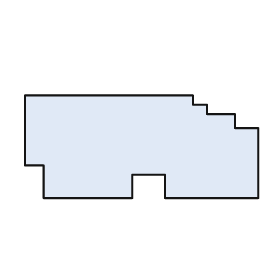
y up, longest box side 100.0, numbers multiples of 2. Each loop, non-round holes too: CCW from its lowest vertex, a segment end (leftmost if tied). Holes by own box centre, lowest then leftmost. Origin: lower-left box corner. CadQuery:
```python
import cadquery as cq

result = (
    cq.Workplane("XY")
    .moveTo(8.0, 0.0)
    .lineTo(46.0, 0.0)
    .lineTo(46.0, 10.0)
    .lineTo(60.0, 10.0)
    .lineTo(60.0, 0.0)
    .lineTo(100.0, 0.0)
    .lineTo(100.0, 30.0)
    .lineTo(90.0, 30.0)
    .lineTo(90.0, 36.0)
    .lineTo(78.0, 36.0)
    .lineTo(78.0, 40.0)
    .lineTo(72.0, 40.0)
    .lineTo(72.0, 44.0)
    .lineTo(0.0, 44.0)
    .lineTo(0.0, 14.0)
    .lineTo(8.0, 14.0)
    .close()
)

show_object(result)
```